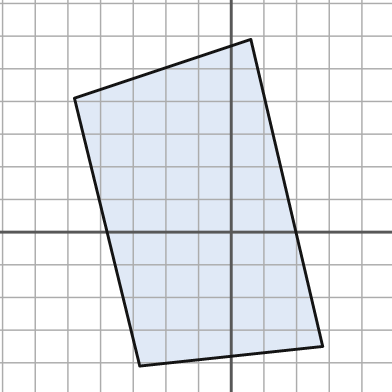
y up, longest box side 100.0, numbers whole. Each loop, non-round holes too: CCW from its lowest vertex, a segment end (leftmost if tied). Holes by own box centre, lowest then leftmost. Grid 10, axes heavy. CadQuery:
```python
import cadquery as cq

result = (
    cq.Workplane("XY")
    .moveTo(-28.0, -41.0)
    .lineTo(28.0, -35.0)
    .lineTo(6.0, 59.0)
    .lineTo(-48.0, 41.0)
    .close()
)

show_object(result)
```